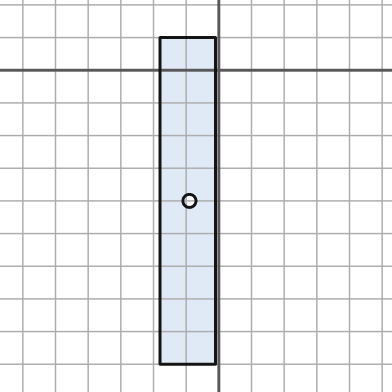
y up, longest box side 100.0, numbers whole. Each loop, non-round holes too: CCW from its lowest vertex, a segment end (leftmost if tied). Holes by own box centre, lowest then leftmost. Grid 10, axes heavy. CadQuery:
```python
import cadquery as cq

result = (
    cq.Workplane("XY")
    .moveTo(-18.0, -90.0)
    .lineTo(-1.0, -90.0)
    .lineTo(-1.0, 10.0)
    .lineTo(-18.0, 10.0)
    .close()
    .moveTo(-9.0, -40.0)
    .circle(2.0)
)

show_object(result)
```